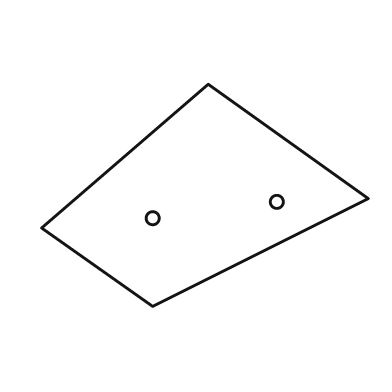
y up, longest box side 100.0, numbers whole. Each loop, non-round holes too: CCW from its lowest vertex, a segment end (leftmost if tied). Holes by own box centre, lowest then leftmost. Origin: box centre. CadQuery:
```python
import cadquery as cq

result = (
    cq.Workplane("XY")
    .moveTo(-16.0, -34.0)
    .lineTo(50.0, -1.0)
    .lineTo(1.0, 34.0)
    .lineTo(-50.0, -10.0)
    .close()
    .moveTo(-16.0, -7.0)
    .circle(2.0)
    .moveTo(22.0, -2.0)
    .circle(2.0)
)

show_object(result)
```